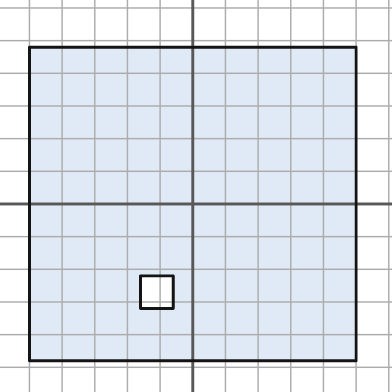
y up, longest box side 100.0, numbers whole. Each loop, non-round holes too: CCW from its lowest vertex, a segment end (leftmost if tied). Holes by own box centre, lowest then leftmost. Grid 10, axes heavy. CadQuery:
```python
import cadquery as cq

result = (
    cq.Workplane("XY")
    .moveTo(-50.0, -48.0)
    .lineTo(50.0, -48.0)
    .lineTo(50.0, 48.0)
    .lineTo(-50.0, 48.0)
    .close()
    .moveTo(-16.0, -32.0)
    .lineTo(-6.0, -32.0)
    .lineTo(-6.0, -22.0)
    .lineTo(-16.0, -22.0)
    .close()
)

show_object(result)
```